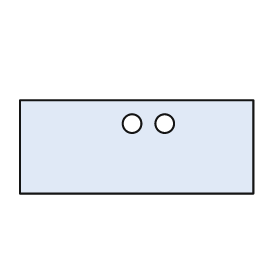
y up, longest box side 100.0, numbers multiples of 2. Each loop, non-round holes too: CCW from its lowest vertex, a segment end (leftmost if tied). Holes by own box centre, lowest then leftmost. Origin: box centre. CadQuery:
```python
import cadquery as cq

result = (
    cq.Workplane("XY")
    .moveTo(-50.0, -20.0)
    .lineTo(50.0, -20.0)
    .lineTo(50.0, 20.0)
    .lineTo(-50.0, 20.0)
    .close()
    .moveTo(-2.0, 10.0)
    .circle(4.0)
    .moveTo(12.0, 10.0)
    .circle(4.0)
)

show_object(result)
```